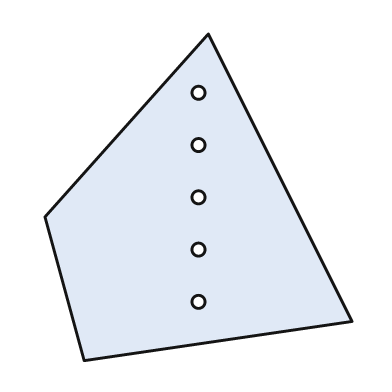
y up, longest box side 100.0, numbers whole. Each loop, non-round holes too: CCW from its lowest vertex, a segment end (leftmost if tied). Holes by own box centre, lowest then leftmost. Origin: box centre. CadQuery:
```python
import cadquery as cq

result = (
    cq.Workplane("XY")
    .moveTo(-35.0, -50.0)
    .lineTo(47.0, -38.0)
    .lineTo(3.0, 50.0)
    .lineTo(-47.0, -6.0)
    .close()
    .moveTo(0.0, -32.0)
    .circle(2.0)
    .moveTo(0.0, -16.0)
    .circle(2.0)
    .moveTo(0.0, 0.0)
    .circle(2.0)
    .moveTo(0.0, 16.0)
    .circle(2.0)
    .moveTo(0.0, 32.0)
    .circle(2.0)
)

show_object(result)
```